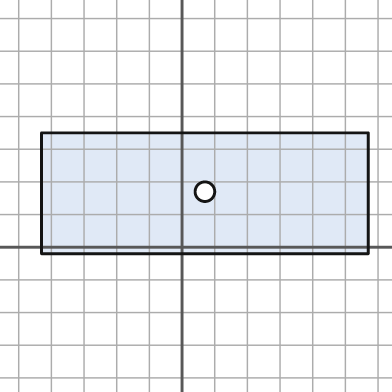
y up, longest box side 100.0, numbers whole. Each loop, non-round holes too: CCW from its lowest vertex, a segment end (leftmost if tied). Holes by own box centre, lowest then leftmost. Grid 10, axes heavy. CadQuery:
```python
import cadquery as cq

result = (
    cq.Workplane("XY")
    .moveTo(-43.0, -2.0)
    .lineTo(57.0, -2.0)
    .lineTo(57.0, 35.0)
    .lineTo(-43.0, 35.0)
    .close()
    .moveTo(7.0, 17.0)
    .circle(3.0)
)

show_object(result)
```